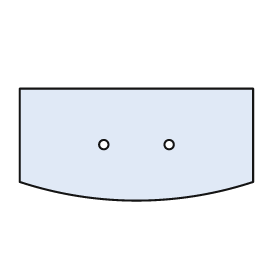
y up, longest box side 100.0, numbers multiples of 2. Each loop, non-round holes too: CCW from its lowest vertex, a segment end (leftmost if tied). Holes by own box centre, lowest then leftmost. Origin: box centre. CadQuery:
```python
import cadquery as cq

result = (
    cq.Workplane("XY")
    .moveTo(-50.0, -16.0)
    .threePointArc((0.0, -24.0), (50.0, -16.0))
    .lineTo(50.0, 24.0)
    .lineTo(-50.0, 24.0)
    .close()
    .moveTo(-14.0, 0.0)
    .circle(2.0)
    .moveTo(14.0, 0.0)
    .circle(2.0)
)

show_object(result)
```